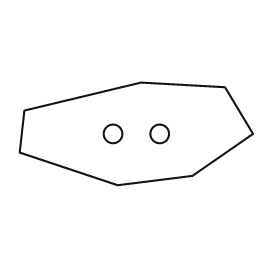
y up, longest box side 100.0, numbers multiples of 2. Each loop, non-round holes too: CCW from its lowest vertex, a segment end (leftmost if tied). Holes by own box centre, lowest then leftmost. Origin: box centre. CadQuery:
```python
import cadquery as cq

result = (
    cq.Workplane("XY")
    .moveTo(-8.0, -22.0)
    .lineTo(24.0, -18.0)
    .lineTo(50.0, 0.0)
    .lineTo(38.0, 20.0)
    .lineTo(2.0, 22.0)
    .lineTo(-48.0, 10.0)
    .lineTo(-50.0, -8.0)
    .close()
    .moveTo(-10.0, 0.0)
    .circle(4.0)
    .moveTo(10.0, 0.0)
    .circle(4.0)
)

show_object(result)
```